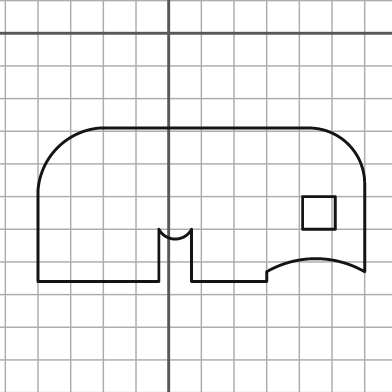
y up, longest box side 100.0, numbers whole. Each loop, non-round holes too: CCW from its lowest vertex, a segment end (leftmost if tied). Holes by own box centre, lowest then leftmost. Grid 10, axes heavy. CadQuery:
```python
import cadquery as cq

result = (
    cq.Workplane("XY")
    .moveTo(-40.0, -76.0)
    .lineTo(-3.0, -76.0)
    .lineTo(-3.0, -60.0)
    .threePointArc((2.0, -63.0), (7.0, -60.0))
    .lineTo(7.0, -76.0)
    .lineTo(30.0, -76.0)
    .lineTo(30.0, -73.0)
    .threePointArc((45.0, -69.0), (60.0, -73.0))
    .lineTo(60.0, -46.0)
    .threePointArc((55.0, -34.0), (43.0, -29.0))
    .lineTo(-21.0, -29.0)
    .threePointArc((-34.0, -35.0), (-40.0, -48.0))
    .close()
    .moveTo(41.0, -60.0)
    .lineTo(51.0, -60.0)
    .lineTo(51.0, -50.0)
    .lineTo(41.0, -50.0)
    .close()
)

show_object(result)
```